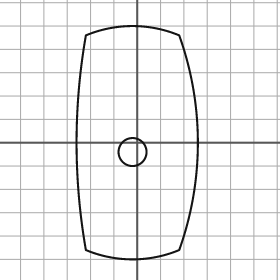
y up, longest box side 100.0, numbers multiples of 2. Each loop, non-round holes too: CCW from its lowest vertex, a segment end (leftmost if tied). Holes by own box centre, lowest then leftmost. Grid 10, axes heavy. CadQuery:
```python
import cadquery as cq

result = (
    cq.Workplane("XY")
    .moveTo(-22.0, -46.0)
    .threePointArc((-2.0, -50.0), (18.0, -46.0))
    .threePointArc((26.0, 0.0), (18.0, 46.0))
    .threePointArc((-2.0, 50.0), (-22.0, 46.0))
    .threePointArc((-26.0, 0.0), (-22.0, -46.0))
    .close()
    .moveTo(-2.0, -4.0)
    .circle(6.0)
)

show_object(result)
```